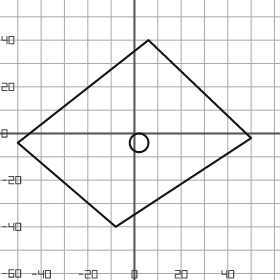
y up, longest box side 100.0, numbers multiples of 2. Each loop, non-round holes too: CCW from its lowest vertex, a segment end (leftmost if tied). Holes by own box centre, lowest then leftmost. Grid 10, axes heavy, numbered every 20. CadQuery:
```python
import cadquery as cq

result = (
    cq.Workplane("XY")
    .moveTo(-8.0, -40.0)
    .lineTo(50.0, -2.0)
    .lineTo(6.0, 40.0)
    .lineTo(-50.0, -4.0)
    .close()
    .moveTo(2.0, -4.0)
    .circle(4.0)
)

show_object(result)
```